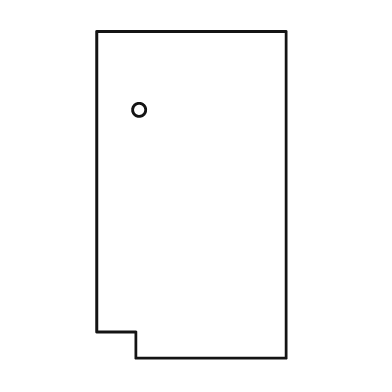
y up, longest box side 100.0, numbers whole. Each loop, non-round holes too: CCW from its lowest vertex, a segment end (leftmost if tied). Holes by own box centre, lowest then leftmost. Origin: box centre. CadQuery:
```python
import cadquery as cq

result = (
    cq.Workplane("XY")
    .moveTo(-17.0, -50.0)
    .lineTo(29.0, -50.0)
    .lineTo(29.0, 50.0)
    .lineTo(-29.0, 50.0)
    .lineTo(-29.0, -42.0)
    .lineTo(-17.0, -42.0)
    .close()
    .moveTo(-16.0, 26.0)
    .circle(2.0)
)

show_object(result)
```